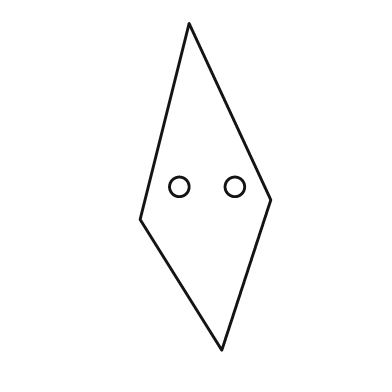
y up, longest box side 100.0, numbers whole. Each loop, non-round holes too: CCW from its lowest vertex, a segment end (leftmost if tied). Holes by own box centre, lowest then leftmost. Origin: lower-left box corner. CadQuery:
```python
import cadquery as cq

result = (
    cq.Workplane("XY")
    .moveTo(25.0, 0.0)
    .lineTo(40.0, 46.0)
    .lineTo(15.0, 100.0)
    .lineTo(0.0, 40.0)
    .close()
    .moveTo(12.0, 50.0)
    .circle(3.0)
    .moveTo(29.0, 50.0)
    .circle(3.0)
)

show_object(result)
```